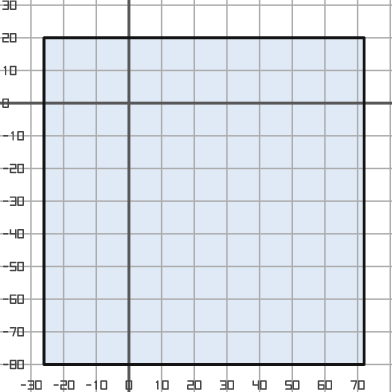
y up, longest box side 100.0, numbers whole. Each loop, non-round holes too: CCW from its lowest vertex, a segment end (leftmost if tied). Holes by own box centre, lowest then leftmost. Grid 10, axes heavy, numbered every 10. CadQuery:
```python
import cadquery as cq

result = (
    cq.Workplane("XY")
    .moveTo(-26.0, -80.0)
    .lineTo(72.0, -80.0)
    .lineTo(72.0, 20.0)
    .lineTo(-26.0, 20.0)
    .close()
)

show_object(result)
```